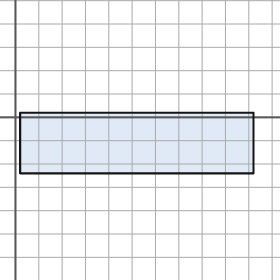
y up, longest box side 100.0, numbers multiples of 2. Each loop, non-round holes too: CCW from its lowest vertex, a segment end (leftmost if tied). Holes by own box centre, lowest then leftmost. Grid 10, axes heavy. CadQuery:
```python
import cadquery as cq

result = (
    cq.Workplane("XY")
    .moveTo(2.0, -24.0)
    .lineTo(102.0, -24.0)
    .lineTo(102.0, 2.0)
    .lineTo(2.0, 2.0)
    .close()
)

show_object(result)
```